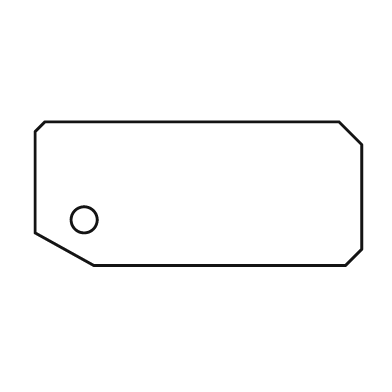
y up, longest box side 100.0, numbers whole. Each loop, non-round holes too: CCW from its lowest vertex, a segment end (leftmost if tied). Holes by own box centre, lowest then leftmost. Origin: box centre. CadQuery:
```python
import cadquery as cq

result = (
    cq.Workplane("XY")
    .moveTo(-32.0, -22.0)
    .lineTo(45.0, -22.0)
    .lineTo(50.0, -17.0)
    .lineTo(50.0, 15.0)
    .lineTo(43.0, 22.0)
    .lineTo(-47.0, 22.0)
    .lineTo(-50.0, 19.0)
    .lineTo(-50.0, -12.0)
    .close()
    .moveTo(-35.0, -8.0)
    .circle(4.0)
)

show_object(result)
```